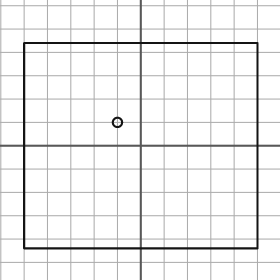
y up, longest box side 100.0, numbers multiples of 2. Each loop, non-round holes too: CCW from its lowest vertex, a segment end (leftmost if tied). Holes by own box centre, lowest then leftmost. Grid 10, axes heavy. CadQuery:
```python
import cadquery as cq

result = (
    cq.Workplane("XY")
    .moveTo(-50.0, -44.0)
    .lineTo(50.0, -44.0)
    .lineTo(50.0, 44.0)
    .lineTo(-50.0, 44.0)
    .close()
    .moveTo(-10.0, 10.0)
    .circle(2.0)
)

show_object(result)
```